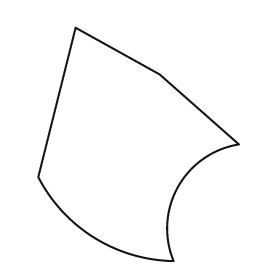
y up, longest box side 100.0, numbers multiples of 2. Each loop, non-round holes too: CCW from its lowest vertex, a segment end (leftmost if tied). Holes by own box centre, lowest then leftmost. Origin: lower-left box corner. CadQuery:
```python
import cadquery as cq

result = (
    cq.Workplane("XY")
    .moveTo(58.0, 0.0)
    .threePointArc((60.0, 32.0), (86.0, 50.0))
    .lineTo(52.0, 80.0)
    .lineTo(16.0, 100.0)
    .lineTo(0.0, 36.0)
    .threePointArc((24.0, 10.0), (58.0, 0.0))
    .close()
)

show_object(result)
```